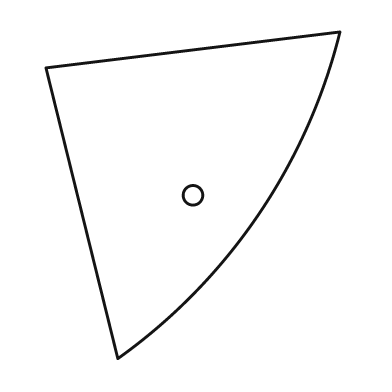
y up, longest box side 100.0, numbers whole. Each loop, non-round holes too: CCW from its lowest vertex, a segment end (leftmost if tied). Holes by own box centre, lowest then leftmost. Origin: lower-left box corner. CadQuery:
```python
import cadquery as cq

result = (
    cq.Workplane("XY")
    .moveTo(22.0, 0.0)
    .threePointArc((65.0, 44.0), (90.0, 100.0))
    .lineTo(0.0, 89.0)
    .close()
    .moveTo(45.0, 50.0)
    .circle(3.0)
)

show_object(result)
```